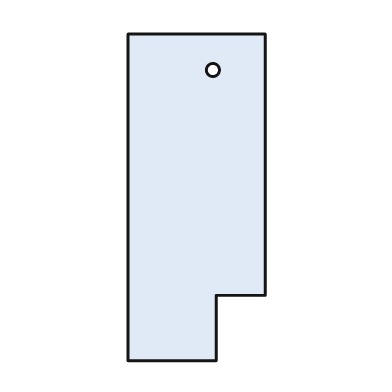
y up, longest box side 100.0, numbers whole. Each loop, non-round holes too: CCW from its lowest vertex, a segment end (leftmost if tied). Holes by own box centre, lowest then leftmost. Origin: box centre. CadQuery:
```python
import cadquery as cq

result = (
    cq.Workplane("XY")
    .moveTo(-21.0, -50.0)
    .lineTo(6.0, -50.0)
    .lineTo(6.0, -30.0)
    .lineTo(21.0, -30.0)
    .lineTo(21.0, 50.0)
    .lineTo(-21.0, 50.0)
    .close()
    .moveTo(5.0, 39.0)
    .circle(2.0)
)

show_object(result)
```